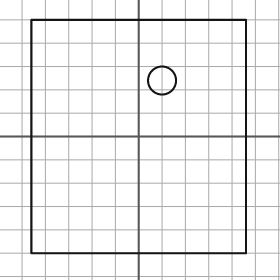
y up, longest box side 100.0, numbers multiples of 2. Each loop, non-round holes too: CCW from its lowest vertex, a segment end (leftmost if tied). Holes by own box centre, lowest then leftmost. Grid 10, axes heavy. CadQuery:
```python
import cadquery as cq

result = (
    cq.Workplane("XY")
    .moveTo(-46.0, -50.0)
    .lineTo(46.0, -50.0)
    .lineTo(46.0, 50.0)
    .lineTo(-46.0, 50.0)
    .close()
    .moveTo(10.0, 24.0)
    .circle(6.0)
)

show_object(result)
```